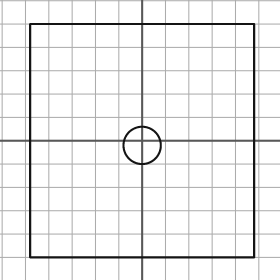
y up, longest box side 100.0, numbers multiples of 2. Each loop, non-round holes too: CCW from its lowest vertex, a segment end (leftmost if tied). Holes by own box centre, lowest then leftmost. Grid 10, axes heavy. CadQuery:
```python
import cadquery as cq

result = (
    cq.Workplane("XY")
    .moveTo(-48.0, -50.0)
    .lineTo(48.0, -50.0)
    .lineTo(48.0, 50.0)
    .lineTo(-48.0, 50.0)
    .close()
    .moveTo(0.0, -2.0)
    .circle(8.0)
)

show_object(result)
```